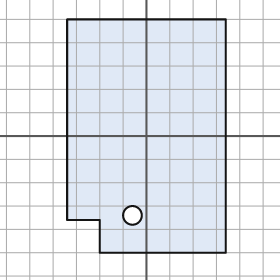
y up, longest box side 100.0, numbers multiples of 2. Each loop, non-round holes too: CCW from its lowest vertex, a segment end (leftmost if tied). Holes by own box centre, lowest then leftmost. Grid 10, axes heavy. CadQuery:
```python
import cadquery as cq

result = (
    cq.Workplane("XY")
    .moveTo(-20.0, -50.0)
    .lineTo(34.0, -50.0)
    .lineTo(34.0, 50.0)
    .lineTo(-34.0, 50.0)
    .lineTo(-34.0, -36.0)
    .lineTo(-20.0, -36.0)
    .close()
    .moveTo(-6.0, -34.0)
    .circle(4.0)
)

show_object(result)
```